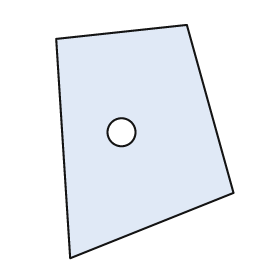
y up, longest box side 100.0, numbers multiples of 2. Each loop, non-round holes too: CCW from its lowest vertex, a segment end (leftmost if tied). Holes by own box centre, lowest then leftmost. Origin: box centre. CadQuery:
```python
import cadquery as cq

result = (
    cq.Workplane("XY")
    .moveTo(-32.0, -50.0)
    .lineTo(38.0, -22.0)
    .lineTo(18.0, 50.0)
    .lineTo(-38.0, 44.0)
    .close()
    .moveTo(-10.0, 4.0)
    .circle(6.0)
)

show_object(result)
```